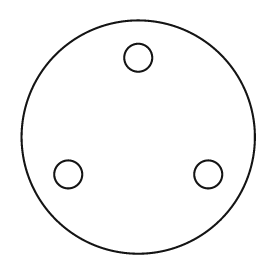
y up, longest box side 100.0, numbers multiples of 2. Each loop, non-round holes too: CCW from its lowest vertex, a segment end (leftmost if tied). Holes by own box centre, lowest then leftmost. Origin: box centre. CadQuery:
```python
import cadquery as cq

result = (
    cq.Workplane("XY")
    .moveTo(0.0, 0.0)
    .circle(50.0)
    .moveTo(-30.0, -16.0)
    .circle(6.0)
    .moveTo(30.0, -16.0)
    .circle(6.0)
    .moveTo(0.0, 34.0)
    .circle(6.0)
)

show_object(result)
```